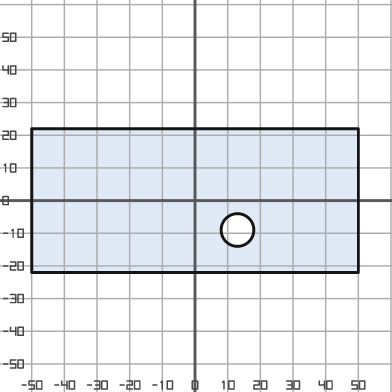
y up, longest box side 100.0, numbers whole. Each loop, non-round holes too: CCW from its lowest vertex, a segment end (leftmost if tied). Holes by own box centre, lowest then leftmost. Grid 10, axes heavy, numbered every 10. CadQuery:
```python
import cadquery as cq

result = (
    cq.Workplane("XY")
    .moveTo(-50.0, -22.0)
    .lineTo(50.0, -22.0)
    .lineTo(50.0, 22.0)
    .lineTo(-50.0, 22.0)
    .close()
    .moveTo(13.0, -9.0)
    .circle(5.0)
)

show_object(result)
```